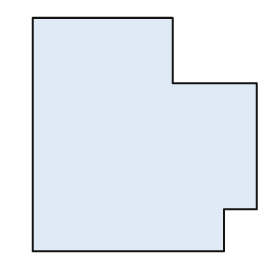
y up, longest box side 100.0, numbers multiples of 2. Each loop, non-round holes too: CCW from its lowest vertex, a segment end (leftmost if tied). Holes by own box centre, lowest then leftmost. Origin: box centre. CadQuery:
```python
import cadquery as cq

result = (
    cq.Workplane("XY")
    .moveTo(-48.0, -50.0)
    .lineTo(34.0, -50.0)
    .lineTo(34.0, -32.0)
    .lineTo(48.0, -32.0)
    .lineTo(48.0, 22.0)
    .lineTo(12.0, 22.0)
    .lineTo(12.0, 50.0)
    .lineTo(-48.0, 50.0)
    .close()
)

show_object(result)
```